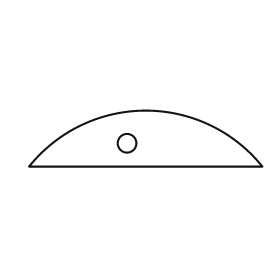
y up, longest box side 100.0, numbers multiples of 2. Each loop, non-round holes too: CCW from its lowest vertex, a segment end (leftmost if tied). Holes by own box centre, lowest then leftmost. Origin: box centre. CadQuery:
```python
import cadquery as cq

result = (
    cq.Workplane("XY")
    .moveTo(-50.0, -12.0)
    .lineTo(50.0, -12.0)
    .threePointArc((0.0, 12.0), (-50.0, -12.0))
    .close()
    .moveTo(-8.0, -2.0)
    .circle(4.0)
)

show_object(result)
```